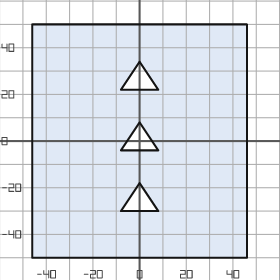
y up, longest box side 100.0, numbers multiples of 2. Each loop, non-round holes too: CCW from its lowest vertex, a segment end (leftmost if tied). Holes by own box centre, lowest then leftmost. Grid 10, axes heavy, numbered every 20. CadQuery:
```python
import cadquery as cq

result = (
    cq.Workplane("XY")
    .moveTo(-46.0, -50.0)
    .lineTo(46.0, -50.0)
    .lineTo(46.0, 50.0)
    .lineTo(-46.0, 50.0)
    .close()
    .moveTo(-8.0, -30.0)
    .lineTo(8.0, -30.0)
    .lineTo(0.0, -18.0)
    .close()
    .moveTo(-8.0, -4.0)
    .lineTo(8.0, -4.0)
    .lineTo(0.0, 8.0)
    .close()
    .moveTo(-8.0, 22.0)
    .lineTo(8.0, 22.0)
    .lineTo(0.0, 34.0)
    .close()
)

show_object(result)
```